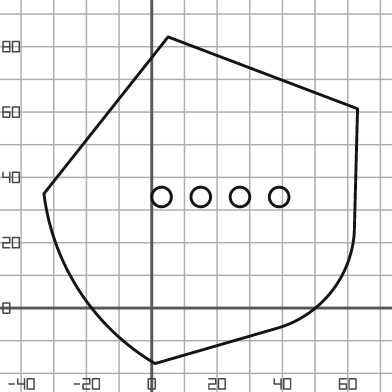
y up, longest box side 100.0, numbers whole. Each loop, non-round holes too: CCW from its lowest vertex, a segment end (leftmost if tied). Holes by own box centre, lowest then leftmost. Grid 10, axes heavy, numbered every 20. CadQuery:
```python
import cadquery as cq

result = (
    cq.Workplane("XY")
    .moveTo(1.0, -17.0)
    .lineTo(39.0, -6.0)
    .threePointArc((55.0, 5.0), (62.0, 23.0))
    .lineTo(63.0, 61.0)
    .lineTo(5.0, 83.0)
    .lineTo(-33.0, 35.0)
    .threePointArc((-22.0, 5.0), (1.0, -17.0))
    .close()
    .moveTo(3.0, 34.0)
    .circle(3.0)
    .moveTo(15.0, 34.0)
    .circle(3.0)
    .moveTo(27.0, 34.0)
    .circle(3.0)
    .moveTo(39.0, 34.0)
    .circle(3.0)
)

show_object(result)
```